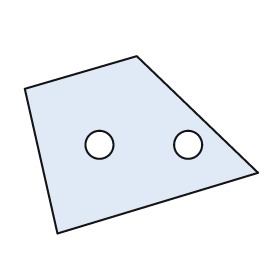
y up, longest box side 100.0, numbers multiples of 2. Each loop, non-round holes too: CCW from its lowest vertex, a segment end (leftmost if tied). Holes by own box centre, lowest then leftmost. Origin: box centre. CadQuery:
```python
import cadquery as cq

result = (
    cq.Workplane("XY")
    .moveTo(-36.0, -38.0)
    .lineTo(50.0, -12.0)
    .lineTo(-2.0, 38.0)
    .lineTo(-50.0, 24.0)
    .close()
    .moveTo(-18.0, 0.0)
    .circle(6.0)
    .moveTo(20.0, 0.0)
    .circle(6.0)
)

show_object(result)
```